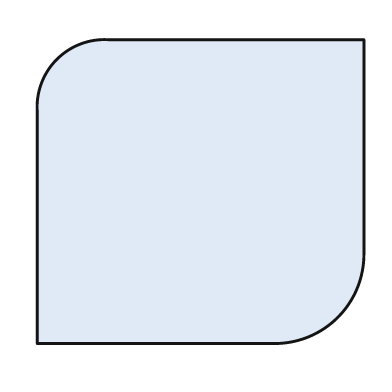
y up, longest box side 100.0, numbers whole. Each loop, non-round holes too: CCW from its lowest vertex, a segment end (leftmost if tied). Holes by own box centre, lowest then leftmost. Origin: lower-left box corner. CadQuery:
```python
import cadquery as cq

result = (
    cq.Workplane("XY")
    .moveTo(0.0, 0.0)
    .lineTo(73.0, 0.0)
    .threePointArc((92.0, 8.0), (100.0, 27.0))
    .lineTo(100.0, 93.0)
    .lineTo(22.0, 93.0)
    .threePointArc((6.0, 87.0), (0.0, 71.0))
    .close()
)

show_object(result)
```